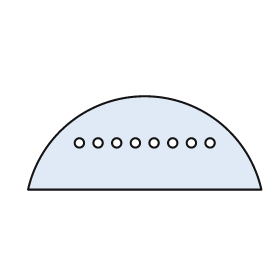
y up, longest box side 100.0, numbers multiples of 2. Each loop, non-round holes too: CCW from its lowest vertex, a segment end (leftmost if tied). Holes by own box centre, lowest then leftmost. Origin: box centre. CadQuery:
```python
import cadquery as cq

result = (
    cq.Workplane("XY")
    .moveTo(-50.0, -20.0)
    .lineTo(50.0, -20.0)
    .threePointArc((0.0, 20.0), (-50.0, -20.0))
    .close()
    .moveTo(-28.0, 0.0)
    .circle(2.0)
    .moveTo(-20.0, 0.0)
    .circle(2.0)
    .moveTo(-12.0, 0.0)
    .circle(2.0)
    .moveTo(-4.0, 0.0)
    .circle(2.0)
    .moveTo(4.0, 0.0)
    .circle(2.0)
    .moveTo(12.0, 0.0)
    .circle(2.0)
    .moveTo(20.0, 0.0)
    .circle(2.0)
    .moveTo(28.0, 0.0)
    .circle(2.0)
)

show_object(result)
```